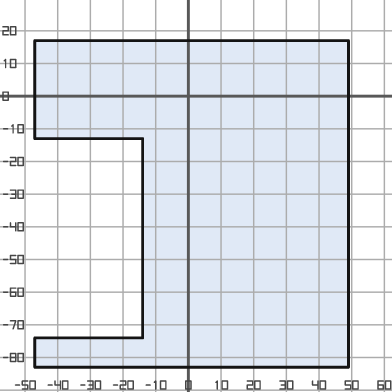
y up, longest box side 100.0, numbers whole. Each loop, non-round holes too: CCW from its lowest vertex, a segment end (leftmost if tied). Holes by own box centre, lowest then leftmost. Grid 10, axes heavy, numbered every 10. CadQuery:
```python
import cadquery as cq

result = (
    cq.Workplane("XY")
    .moveTo(-47.0, -83.0)
    .lineTo(49.0, -83.0)
    .lineTo(49.0, 17.0)
    .lineTo(-47.0, 17.0)
    .lineTo(-47.0, -13.0)
    .lineTo(-14.0, -13.0)
    .lineTo(-14.0, -74.0)
    .lineTo(-47.0, -74.0)
    .close()
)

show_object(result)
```